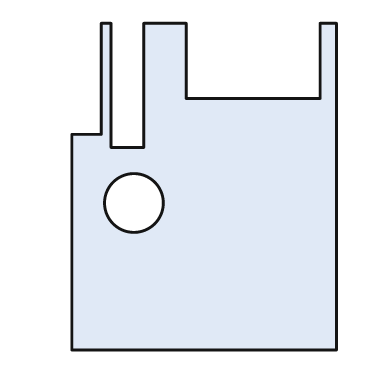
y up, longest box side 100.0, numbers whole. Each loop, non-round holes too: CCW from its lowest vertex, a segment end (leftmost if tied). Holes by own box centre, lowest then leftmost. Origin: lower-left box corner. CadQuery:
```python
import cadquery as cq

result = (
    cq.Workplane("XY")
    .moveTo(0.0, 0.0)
    .lineTo(81.0, 0.0)
    .lineTo(81.0, 100.0)
    .lineTo(76.0, 100.0)
    .lineTo(76.0, 77.0)
    .lineTo(35.0, 77.0)
    .lineTo(35.0, 100.0)
    .lineTo(22.0, 100.0)
    .lineTo(22.0, 62.0)
    .lineTo(12.0, 62.0)
    .lineTo(12.0, 100.0)
    .lineTo(9.0, 100.0)
    .lineTo(9.0, 66.0)
    .lineTo(0.0, 66.0)
    .close()
    .moveTo(19.0, 45.0)
    .circle(9.0)
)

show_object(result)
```